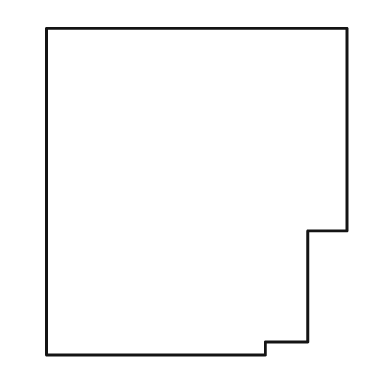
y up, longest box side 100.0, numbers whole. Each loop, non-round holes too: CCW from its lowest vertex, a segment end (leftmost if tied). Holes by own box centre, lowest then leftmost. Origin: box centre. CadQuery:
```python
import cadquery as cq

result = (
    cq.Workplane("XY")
    .moveTo(-46.0, -50.0)
    .lineTo(21.0, -50.0)
    .lineTo(21.0, -46.0)
    .lineTo(34.0, -46.0)
    .lineTo(34.0, -12.0)
    .lineTo(46.0, -12.0)
    .lineTo(46.0, 50.0)
    .lineTo(-46.0, 50.0)
    .close()
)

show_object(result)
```